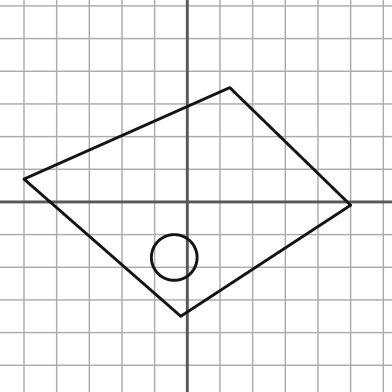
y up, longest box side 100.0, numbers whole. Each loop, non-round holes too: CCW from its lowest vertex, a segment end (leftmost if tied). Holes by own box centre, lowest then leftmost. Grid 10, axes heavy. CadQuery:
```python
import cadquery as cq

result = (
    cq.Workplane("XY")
    .moveTo(-2.0, -35.0)
    .lineTo(50.0, -1.0)
    .lineTo(13.0, 35.0)
    .lineTo(-50.0, 7.0)
    .close()
    .moveTo(-4.0, -17.0)
    .circle(7.0)
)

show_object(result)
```